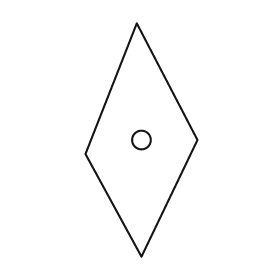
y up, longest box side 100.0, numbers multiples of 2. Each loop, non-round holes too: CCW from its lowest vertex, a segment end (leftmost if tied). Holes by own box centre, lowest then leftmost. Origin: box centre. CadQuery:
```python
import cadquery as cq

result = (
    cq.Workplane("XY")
    .moveTo(0.0, -50.0)
    .lineTo(24.0, 0.0)
    .lineTo(-2.0, 50.0)
    .lineTo(-24.0, -6.0)
    .close()
    .moveTo(0.0, 0.0)
    .circle(4.0)
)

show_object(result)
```